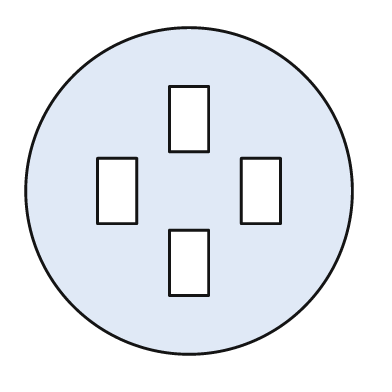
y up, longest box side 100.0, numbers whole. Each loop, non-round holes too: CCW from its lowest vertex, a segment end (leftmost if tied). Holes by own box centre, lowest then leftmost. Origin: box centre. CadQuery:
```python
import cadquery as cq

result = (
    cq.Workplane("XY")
    .moveTo(0.0, 0.0)
    .circle(50.0)
    .moveTo(-6.0, -32.0)
    .lineTo(6.0, -32.0)
    .lineTo(6.0, -12.0)
    .lineTo(-6.0, -12.0)
    .close()
    .moveTo(-28.0, -10.0)
    .lineTo(-16.0, -10.0)
    .lineTo(-16.0, 10.0)
    .lineTo(-28.0, 10.0)
    .close()
    .moveTo(16.0, -10.0)
    .lineTo(28.0, -10.0)
    .lineTo(28.0, 10.0)
    .lineTo(16.0, 10.0)
    .close()
    .moveTo(-6.0, 12.0)
    .lineTo(6.0, 12.0)
    .lineTo(6.0, 32.0)
    .lineTo(-6.0, 32.0)
    .close()
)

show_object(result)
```